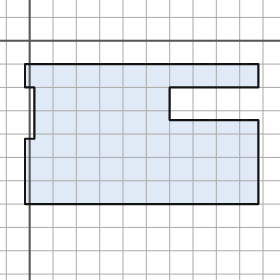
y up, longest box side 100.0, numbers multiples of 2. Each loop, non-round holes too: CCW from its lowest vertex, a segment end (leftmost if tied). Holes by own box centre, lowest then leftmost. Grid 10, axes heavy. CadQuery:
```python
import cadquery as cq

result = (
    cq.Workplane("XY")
    .moveTo(-2.0, -70.0)
    .lineTo(98.0, -70.0)
    .lineTo(98.0, -34.0)
    .lineTo(60.0, -34.0)
    .lineTo(60.0, -20.0)
    .lineTo(98.0, -20.0)
    .lineTo(98.0, -10.0)
    .lineTo(-2.0, -10.0)
    .lineTo(-2.0, -20.0)
    .lineTo(2.0, -20.0)
    .lineTo(2.0, -42.0)
    .lineTo(-2.0, -42.0)
    .close()
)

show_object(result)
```